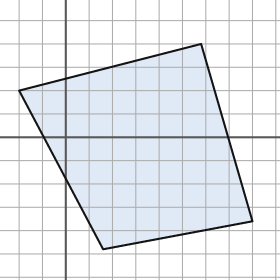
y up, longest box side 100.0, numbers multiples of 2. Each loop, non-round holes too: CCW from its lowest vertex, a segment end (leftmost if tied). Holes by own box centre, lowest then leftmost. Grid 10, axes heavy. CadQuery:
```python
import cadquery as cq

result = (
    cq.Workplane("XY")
    .moveTo(16.0, -48.0)
    .lineTo(80.0, -36.0)
    .lineTo(58.0, 40.0)
    .lineTo(-20.0, 20.0)
    .close()
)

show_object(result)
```